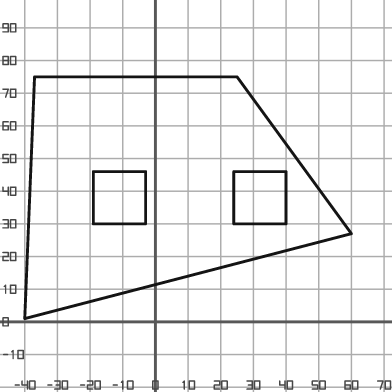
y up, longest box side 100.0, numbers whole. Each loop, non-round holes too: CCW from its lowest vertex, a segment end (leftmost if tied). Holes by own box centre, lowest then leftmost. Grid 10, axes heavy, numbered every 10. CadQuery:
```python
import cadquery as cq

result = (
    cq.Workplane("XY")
    .moveTo(-40.0, 1.0)
    .lineTo(60.0, 27.0)
    .lineTo(25.0, 75.0)
    .lineTo(-37.0, 75.0)
    .close()
    .moveTo(-19.0, 30.0)
    .lineTo(-3.0, 30.0)
    .lineTo(-3.0, 46.0)
    .lineTo(-19.0, 46.0)
    .close()
    .moveTo(24.0, 30.0)
    .lineTo(40.0, 30.0)
    .lineTo(40.0, 46.0)
    .lineTo(24.0, 46.0)
    .close()
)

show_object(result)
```